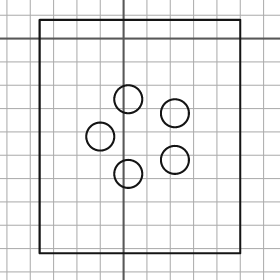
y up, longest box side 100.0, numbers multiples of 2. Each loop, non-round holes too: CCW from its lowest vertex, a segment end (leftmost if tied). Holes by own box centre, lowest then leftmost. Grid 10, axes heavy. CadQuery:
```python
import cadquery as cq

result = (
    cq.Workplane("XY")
    .moveTo(-36.0, -92.0)
    .lineTo(50.0, -92.0)
    .lineTo(50.0, 8.0)
    .lineTo(-36.0, 8.0)
    .close()
    .moveTo(2.0, -58.0)
    .circle(6.0)
    .moveTo(22.0, -52.0)
    .circle(6.0)
    .moveTo(-10.0, -42.0)
    .circle(6.0)
    .moveTo(22.0, -32.0)
    .circle(6.0)
    .moveTo(2.0, -26.0)
    .circle(6.0)
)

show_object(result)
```